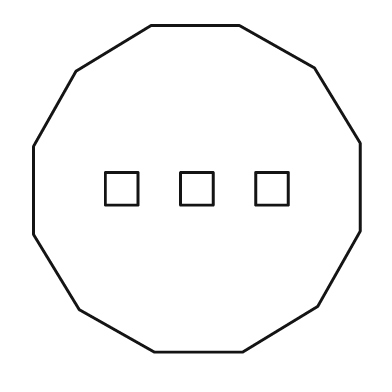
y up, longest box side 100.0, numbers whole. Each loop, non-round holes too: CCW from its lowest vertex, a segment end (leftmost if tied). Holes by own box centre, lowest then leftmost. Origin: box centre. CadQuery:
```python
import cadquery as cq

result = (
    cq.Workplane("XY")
    .moveTo(-13.0, -50.0)
    .lineTo(14.0, -50.0)
    .lineTo(37.0, -36.0)
    .lineTo(50.0, -13.0)
    .lineTo(50.0, 14.0)
    .lineTo(36.0, 37.0)
    .lineTo(13.0, 50.0)
    .lineTo(-14.0, 50.0)
    .lineTo(-37.0, 36.0)
    .lineTo(-50.0, 13.0)
    .lineTo(-50.0, -14.0)
    .lineTo(-36.0, -37.0)
    .close()
    .moveTo(-28.0, -5.0)
    .lineTo(-18.0, -5.0)
    .lineTo(-18.0, 5.0)
    .lineTo(-28.0, 5.0)
    .close()
    .moveTo(-5.0, -5.0)
    .lineTo(5.0, -5.0)
    .lineTo(5.0, 5.0)
    .lineTo(-5.0, 5.0)
    .close()
    .moveTo(18.0, -5.0)
    .lineTo(28.0, -5.0)
    .lineTo(28.0, 5.0)
    .lineTo(18.0, 5.0)
    .close()
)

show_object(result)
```